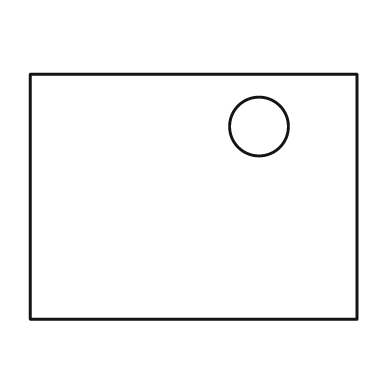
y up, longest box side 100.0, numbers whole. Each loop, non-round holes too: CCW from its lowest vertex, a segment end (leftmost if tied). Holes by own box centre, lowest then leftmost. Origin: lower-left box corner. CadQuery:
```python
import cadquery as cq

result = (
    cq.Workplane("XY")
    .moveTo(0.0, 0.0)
    .lineTo(100.0, 0.0)
    .lineTo(100.0, 75.0)
    .lineTo(0.0, 75.0)
    .close()
    .moveTo(70.0, 59.0)
    .circle(9.0)
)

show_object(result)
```